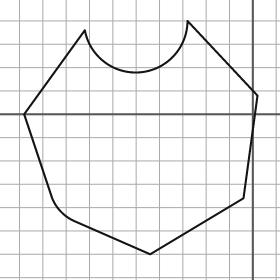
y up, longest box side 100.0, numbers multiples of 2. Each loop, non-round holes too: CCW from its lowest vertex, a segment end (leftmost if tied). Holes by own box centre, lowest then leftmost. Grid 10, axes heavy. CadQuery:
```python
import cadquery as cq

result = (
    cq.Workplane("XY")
    .moveTo(-44.0, -60.0)
    .lineTo(-4.0, -36.0)
    .lineTo(2.0, 8.0)
    .lineTo(-28.0, 40.0)
    .threePointArc((-48.0, 18.0), (-72.0, 36.0))
    .lineTo(-98.0, 0.0)
    .lineTo(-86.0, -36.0)
    .threePointArc((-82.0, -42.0), (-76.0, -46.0))
    .close()
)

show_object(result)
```